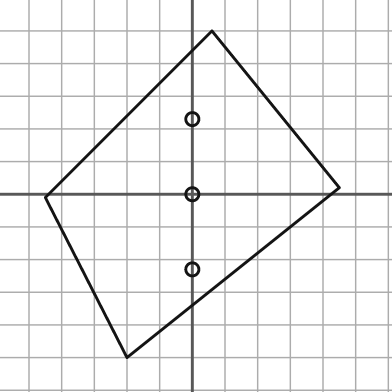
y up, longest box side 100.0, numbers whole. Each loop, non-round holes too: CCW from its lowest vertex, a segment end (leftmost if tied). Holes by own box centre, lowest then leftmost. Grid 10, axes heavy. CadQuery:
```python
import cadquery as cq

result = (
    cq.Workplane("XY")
    .moveTo(-20.0, -50.0)
    .lineTo(45.0, 2.0)
    .lineTo(6.0, 50.0)
    .lineTo(-45.0, -1.0)
    .close()
    .moveTo(0.0, -23.0)
    .circle(2.0)
    .moveTo(0.0, 0.0)
    .circle(2.0)
    .moveTo(0.0, 23.0)
    .circle(2.0)
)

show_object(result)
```